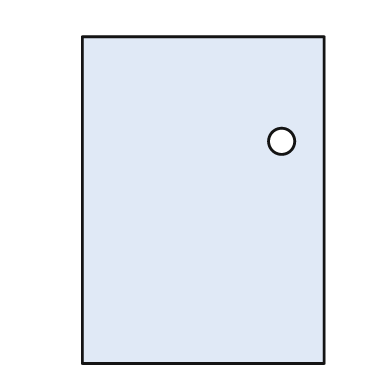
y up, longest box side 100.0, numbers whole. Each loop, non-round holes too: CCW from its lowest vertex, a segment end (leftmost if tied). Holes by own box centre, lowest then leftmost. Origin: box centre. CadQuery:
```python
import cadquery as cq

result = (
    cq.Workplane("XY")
    .moveTo(-37.0, -50.0)
    .lineTo(37.0, -50.0)
    .lineTo(37.0, 50.0)
    .lineTo(-37.0, 50.0)
    .close()
    .moveTo(24.0, 18.0)
    .circle(4.0)
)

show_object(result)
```